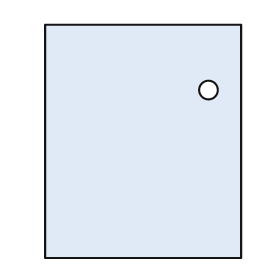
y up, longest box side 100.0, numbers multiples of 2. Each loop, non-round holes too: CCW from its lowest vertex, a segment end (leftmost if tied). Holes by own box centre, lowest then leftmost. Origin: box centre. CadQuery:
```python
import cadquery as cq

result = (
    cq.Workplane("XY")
    .moveTo(-42.0, -50.0)
    .lineTo(42.0, -50.0)
    .lineTo(42.0, 50.0)
    .lineTo(-42.0, 50.0)
    .close()
    .moveTo(28.0, 22.0)
    .circle(4.0)
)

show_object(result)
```